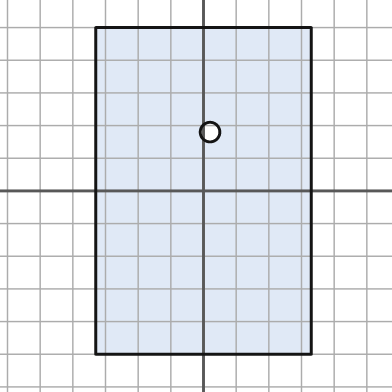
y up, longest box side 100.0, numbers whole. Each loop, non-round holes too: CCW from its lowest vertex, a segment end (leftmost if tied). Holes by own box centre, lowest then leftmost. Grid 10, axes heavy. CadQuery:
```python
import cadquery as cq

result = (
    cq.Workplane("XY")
    .moveTo(-33.0, -50.0)
    .lineTo(33.0, -50.0)
    .lineTo(33.0, 50.0)
    .lineTo(-33.0, 50.0)
    .close()
    .moveTo(2.0, 18.0)
    .circle(3.0)
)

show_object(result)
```